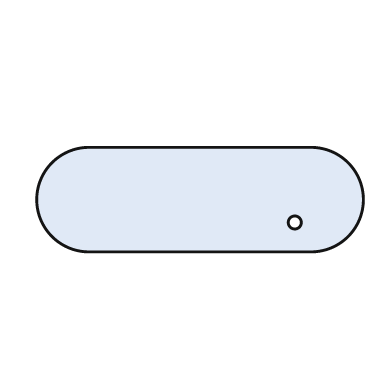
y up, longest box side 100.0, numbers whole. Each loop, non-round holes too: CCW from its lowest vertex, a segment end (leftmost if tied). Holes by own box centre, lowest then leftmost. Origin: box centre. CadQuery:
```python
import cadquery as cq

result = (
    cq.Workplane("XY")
    .moveTo(-34.0, -16.0)
    .lineTo(34.0, -16.0)
    .threePointArc((50.0, 0.0), (34.0, 16.0))
    .lineTo(-34.0, 16.0)
    .threePointArc((-50.0, 0.0), (-34.0, -16.0))
    .close()
    .moveTo(29.0, -7.0)
    .circle(2.0)
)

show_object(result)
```